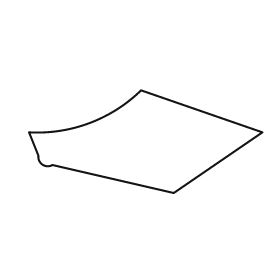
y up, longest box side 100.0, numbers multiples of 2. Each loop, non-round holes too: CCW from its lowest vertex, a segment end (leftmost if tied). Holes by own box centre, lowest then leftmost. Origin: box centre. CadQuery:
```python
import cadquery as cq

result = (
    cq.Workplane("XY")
    .moveTo(12.0, -22.0)
    .lineTo(50.0, 4.0)
    .lineTo(-2.0, 22.0)
    .threePointArc((-24.0, 8.0), (-50.0, 4.0))
    .lineTo(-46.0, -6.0)
    .threePointArc((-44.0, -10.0), (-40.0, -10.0))
    .close()
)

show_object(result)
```